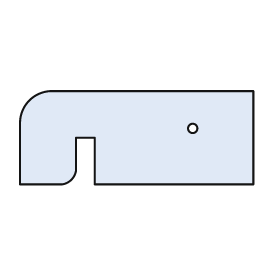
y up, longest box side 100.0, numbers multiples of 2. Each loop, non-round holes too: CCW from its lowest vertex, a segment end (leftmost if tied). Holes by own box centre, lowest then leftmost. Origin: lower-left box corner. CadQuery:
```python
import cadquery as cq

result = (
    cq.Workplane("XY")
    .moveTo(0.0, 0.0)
    .lineTo(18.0, 0.0)
    .threePointArc((22.0, 2.0), (24.0, 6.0))
    .lineTo(24.0, 20.0)
    .lineTo(32.0, 20.0)
    .lineTo(32.0, 0.0)
    .lineTo(100.0, 0.0)
    .lineTo(100.0, 40.0)
    .lineTo(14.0, 40.0)
    .threePointArc((4.0, 36.0), (0.0, 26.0))
    .close()
    .moveTo(74.0, 24.0)
    .circle(2.0)
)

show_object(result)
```